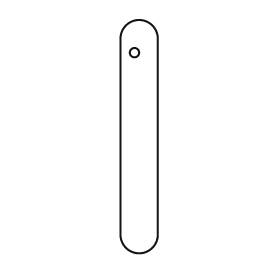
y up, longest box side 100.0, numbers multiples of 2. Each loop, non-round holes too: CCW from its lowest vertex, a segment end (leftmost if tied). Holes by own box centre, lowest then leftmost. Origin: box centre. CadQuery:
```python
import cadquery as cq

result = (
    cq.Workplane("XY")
    .moveTo(-8.0, -42.0)
    .threePointArc((0.0, -50.0), (8.0, -42.0))
    .lineTo(8.0, 42.0)
    .threePointArc((0.0, 50.0), (-8.0, 42.0))
    .close()
    .moveTo(-2.0, 36.0)
    .circle(2.0)
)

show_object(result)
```